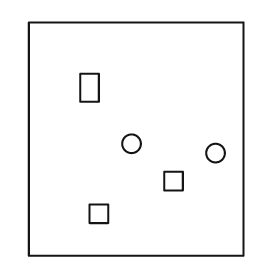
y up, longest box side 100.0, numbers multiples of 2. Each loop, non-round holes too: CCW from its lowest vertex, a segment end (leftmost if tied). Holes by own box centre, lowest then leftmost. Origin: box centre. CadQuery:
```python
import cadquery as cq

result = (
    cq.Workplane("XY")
    .moveTo(-46.0, -50.0)
    .lineTo(46.0, -50.0)
    .lineTo(46.0, 50.0)
    .lineTo(-46.0, 50.0)
    .close()
    .moveTo(-20.0, -36.0)
    .lineTo(-12.0, -36.0)
    .lineTo(-12.0, -28.0)
    .lineTo(-20.0, -28.0)
    .close()
    .moveTo(12.0, -22.0)
    .lineTo(20.0, -22.0)
    .lineTo(20.0, -14.0)
    .lineTo(12.0, -14.0)
    .close()
    .moveTo(34.0, -6.0)
    .circle(4.0)
    .moveTo(-2.0, -2.0)
    .circle(4.0)
    .moveTo(-24.0, 16.0)
    .lineTo(-16.0, 16.0)
    .lineTo(-16.0, 28.0)
    .lineTo(-24.0, 28.0)
    .close()
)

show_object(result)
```